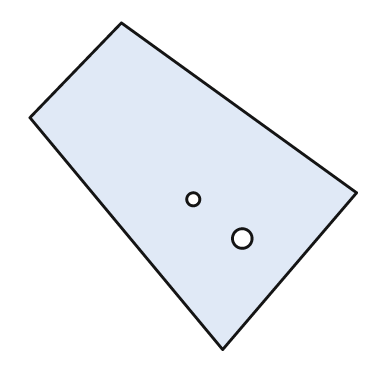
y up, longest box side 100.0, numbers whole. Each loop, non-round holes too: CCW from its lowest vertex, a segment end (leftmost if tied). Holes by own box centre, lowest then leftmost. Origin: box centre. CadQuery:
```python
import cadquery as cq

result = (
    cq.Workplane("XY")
    .moveTo(9.0, -50.0)
    .lineTo(50.0, -2.0)
    .lineTo(-22.0, 50.0)
    .lineTo(-50.0, 21.0)
    .close()
    .moveTo(15.0, -16.0)
    .circle(3.0)
    .moveTo(0.0, -4.0)
    .circle(2.0)
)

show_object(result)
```